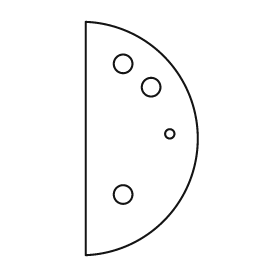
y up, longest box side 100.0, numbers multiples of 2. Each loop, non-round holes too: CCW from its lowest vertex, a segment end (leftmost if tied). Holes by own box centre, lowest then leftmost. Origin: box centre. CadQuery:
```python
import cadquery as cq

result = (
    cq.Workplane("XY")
    .moveTo(-24.0, -50.0)
    .threePointArc((24.0, 0.0), (-24.0, 50.0))
    .close()
    .moveTo(-8.0, -24.0)
    .circle(4.0)
    .moveTo(12.0, 2.0)
    .circle(2.0)
    .moveTo(4.0, 22.0)
    .circle(4.0)
    .moveTo(-8.0, 32.0)
    .circle(4.0)
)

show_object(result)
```